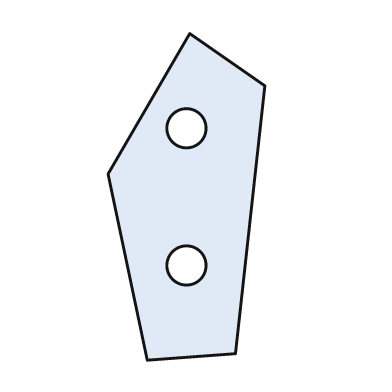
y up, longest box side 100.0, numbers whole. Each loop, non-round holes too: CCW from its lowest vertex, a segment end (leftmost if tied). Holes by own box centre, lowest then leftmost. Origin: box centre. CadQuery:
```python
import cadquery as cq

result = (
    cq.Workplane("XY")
    .moveTo(-12.0, -50.0)
    .lineTo(15.0, -48.0)
    .lineTo(24.0, 34.0)
    .lineTo(1.0, 50.0)
    .lineTo(-24.0, 7.0)
    .close()
    .moveTo(0.0, -21.0)
    .circle(6.0)
    .moveTo(0.0, 21.0)
    .circle(6.0)
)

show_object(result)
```